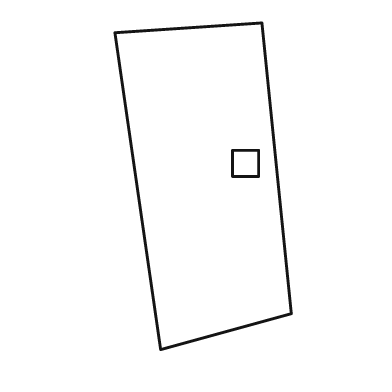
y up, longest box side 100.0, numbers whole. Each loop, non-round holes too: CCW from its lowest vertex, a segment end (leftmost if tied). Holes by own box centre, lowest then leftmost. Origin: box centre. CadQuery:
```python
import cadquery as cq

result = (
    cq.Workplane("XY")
    .moveTo(-13.0, -50.0)
    .lineTo(27.0, -39.0)
    .lineTo(18.0, 50.0)
    .lineTo(-27.0, 47.0)
    .close()
    .moveTo(9.0, 3.0)
    .lineTo(17.0, 3.0)
    .lineTo(17.0, 11.0)
    .lineTo(9.0, 11.0)
    .close()
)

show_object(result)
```